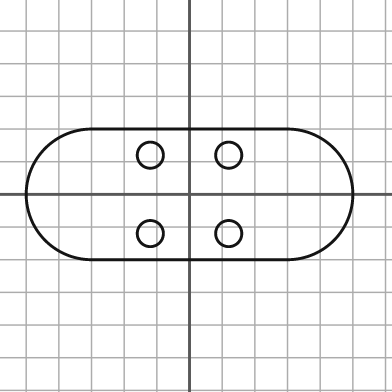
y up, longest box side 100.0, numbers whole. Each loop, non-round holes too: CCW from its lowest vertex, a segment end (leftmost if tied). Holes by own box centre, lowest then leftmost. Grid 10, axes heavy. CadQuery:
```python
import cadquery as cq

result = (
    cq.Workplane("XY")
    .moveTo(-30.0, -20.0)
    .lineTo(30.0, -20.0)
    .threePointArc((50.0, 0.0), (30.0, 20.0))
    .lineTo(-30.0, 20.0)
    .threePointArc((-50.0, 0.0), (-30.0, -20.0))
    .close()
    .moveTo(-12.0, -12.0)
    .circle(4.0)
    .moveTo(12.0, -12.0)
    .circle(4.0)
    .moveTo(-12.0, 12.0)
    .circle(4.0)
    .moveTo(12.0, 12.0)
    .circle(4.0)
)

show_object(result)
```